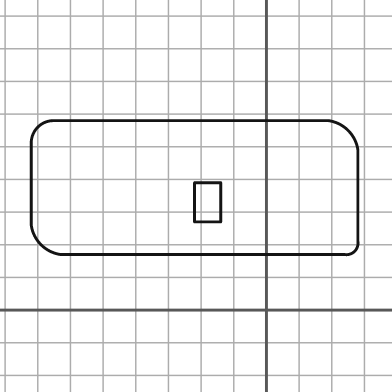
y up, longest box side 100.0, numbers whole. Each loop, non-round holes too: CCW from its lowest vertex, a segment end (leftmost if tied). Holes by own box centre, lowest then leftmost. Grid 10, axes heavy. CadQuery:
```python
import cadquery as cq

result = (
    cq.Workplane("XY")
    .moveTo(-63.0, 17.0)
    .lineTo(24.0, 17.0)
    .threePointArc((27.0, 18.0), (28.0, 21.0))
    .lineTo(28.0, 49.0)
    .threePointArc((25.0, 55.0), (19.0, 58.0))
    .lineTo(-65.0, 58.0)
    .threePointArc((-70.0, 56.0), (-72.0, 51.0))
    .lineTo(-72.0, 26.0)
    .threePointArc((-69.0, 20.0), (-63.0, 17.0))
    .close()
    .moveTo(-22.0, 27.0)
    .lineTo(-14.0, 27.0)
    .lineTo(-14.0, 39.0)
    .lineTo(-22.0, 39.0)
    .close()
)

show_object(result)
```